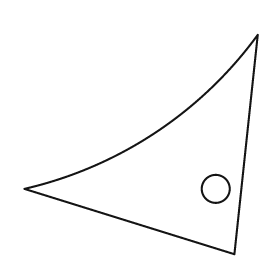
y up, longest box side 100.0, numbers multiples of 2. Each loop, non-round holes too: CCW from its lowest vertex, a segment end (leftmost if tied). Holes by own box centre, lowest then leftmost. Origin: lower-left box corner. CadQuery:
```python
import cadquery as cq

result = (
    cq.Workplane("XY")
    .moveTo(90.0, 0.0)
    .lineTo(100.0, 94.0)
    .threePointArc((56.0, 52.0), (0.0, 28.0))
    .close()
    .moveTo(82.0, 28.0)
    .circle(6.0)
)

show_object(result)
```